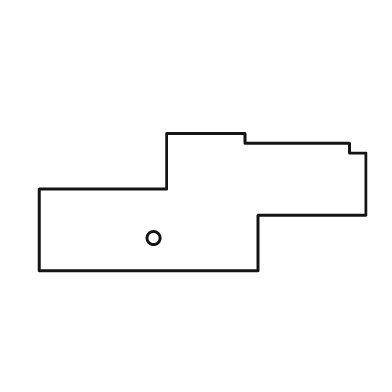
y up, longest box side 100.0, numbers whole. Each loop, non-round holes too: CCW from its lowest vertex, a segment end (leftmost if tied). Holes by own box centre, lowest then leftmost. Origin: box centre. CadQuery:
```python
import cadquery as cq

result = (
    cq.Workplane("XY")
    .moveTo(-50.0, -21.0)
    .lineTo(17.0, -21.0)
    .lineTo(17.0, -4.0)
    .lineTo(50.0, -4.0)
    .lineTo(50.0, 15.0)
    .lineTo(45.0, 15.0)
    .lineTo(45.0, 18.0)
    .lineTo(13.0, 18.0)
    .lineTo(13.0, 21.0)
    .lineTo(-11.0, 21.0)
    .lineTo(-11.0, 4.0)
    .lineTo(-50.0, 4.0)
    .close()
    .moveTo(-15.0, -11.0)
    .circle(2.0)
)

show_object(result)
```